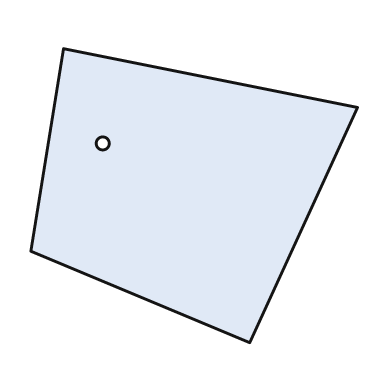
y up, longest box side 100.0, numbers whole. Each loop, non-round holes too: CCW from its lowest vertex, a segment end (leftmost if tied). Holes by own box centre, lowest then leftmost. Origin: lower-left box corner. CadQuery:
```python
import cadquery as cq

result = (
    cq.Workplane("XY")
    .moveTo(67.0, 0.0)
    .lineTo(100.0, 72.0)
    .lineTo(10.0, 90.0)
    .lineTo(0.0, 28.0)
    .close()
    .moveTo(22.0, 61.0)
    .circle(2.0)
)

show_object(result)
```